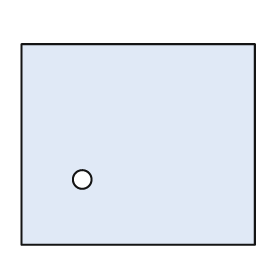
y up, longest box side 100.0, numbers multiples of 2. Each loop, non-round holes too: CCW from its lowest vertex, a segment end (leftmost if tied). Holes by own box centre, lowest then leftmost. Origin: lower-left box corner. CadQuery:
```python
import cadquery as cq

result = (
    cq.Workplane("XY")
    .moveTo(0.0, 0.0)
    .lineTo(100.0, 0.0)
    .lineTo(100.0, 86.0)
    .lineTo(0.0, 86.0)
    .close()
    .moveTo(26.0, 28.0)
    .circle(4.0)
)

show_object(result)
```